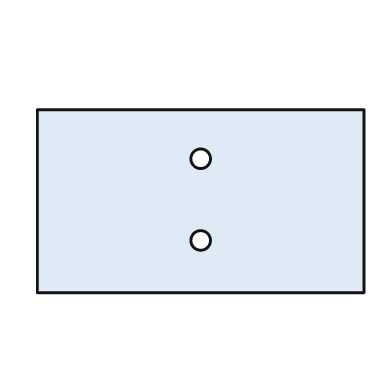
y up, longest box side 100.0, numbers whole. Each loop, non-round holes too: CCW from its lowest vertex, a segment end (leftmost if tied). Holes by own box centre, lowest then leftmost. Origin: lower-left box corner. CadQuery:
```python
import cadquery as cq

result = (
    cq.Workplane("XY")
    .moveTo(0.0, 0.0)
    .lineTo(100.0, 0.0)
    .lineTo(100.0, 56.0)
    .lineTo(0.0, 56.0)
    .close()
    .moveTo(50.0, 16.0)
    .circle(3.0)
    .moveTo(50.0, 41.0)
    .circle(3.0)
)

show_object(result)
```